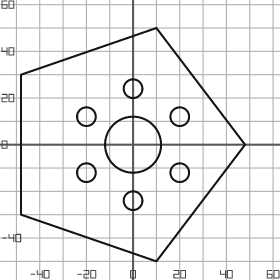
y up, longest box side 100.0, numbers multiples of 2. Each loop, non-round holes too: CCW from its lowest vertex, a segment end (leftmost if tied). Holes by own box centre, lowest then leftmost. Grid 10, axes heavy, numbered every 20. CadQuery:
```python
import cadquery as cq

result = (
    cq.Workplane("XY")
    .moveTo(10.0, -50.0)
    .lineTo(48.0, 0.0)
    .lineTo(10.0, 50.0)
    .lineTo(-48.0, 30.0)
    .lineTo(-48.0, -30.0)
    .close()
    .moveTo(0.0, -24.0)
    .circle(4.0)
    .moveTo(-20.0, -12.0)
    .circle(4.0)
    .moveTo(20.0, -12.0)
    .circle(4.0)
    .moveTo(0.0, 0.0)
    .circle(12.0)
    .moveTo(-20.0, 12.0)
    .circle(4.0)
    .moveTo(20.0, 12.0)
    .circle(4.0)
    .moveTo(0.0, 24.0)
    .circle(4.0)
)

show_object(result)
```